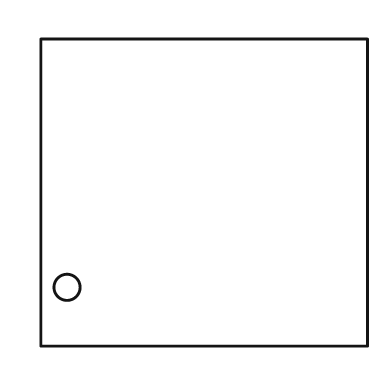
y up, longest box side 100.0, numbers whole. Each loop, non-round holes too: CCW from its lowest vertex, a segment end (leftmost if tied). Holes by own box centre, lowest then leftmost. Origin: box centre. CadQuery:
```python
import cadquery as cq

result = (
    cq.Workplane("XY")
    .moveTo(-50.0, -47.0)
    .lineTo(50.0, -47.0)
    .lineTo(50.0, 47.0)
    .lineTo(-50.0, 47.0)
    .close()
    .moveTo(-42.0, -29.0)
    .circle(4.0)
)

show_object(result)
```